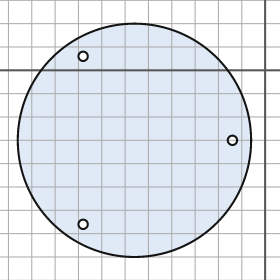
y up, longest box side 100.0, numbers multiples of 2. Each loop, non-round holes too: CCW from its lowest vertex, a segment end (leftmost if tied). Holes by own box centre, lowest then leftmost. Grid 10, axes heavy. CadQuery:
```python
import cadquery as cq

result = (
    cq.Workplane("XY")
    .moveTo(-56.0, -30.0)
    .circle(50.0)
    .moveTo(-78.0, -66.0)
    .circle(2.0)
    .moveTo(-14.0, -30.0)
    .circle(2.0)
    .moveTo(-78.0, 6.0)
    .circle(2.0)
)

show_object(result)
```